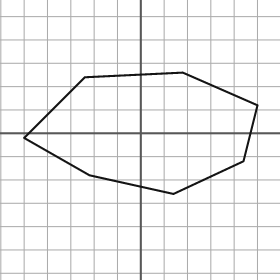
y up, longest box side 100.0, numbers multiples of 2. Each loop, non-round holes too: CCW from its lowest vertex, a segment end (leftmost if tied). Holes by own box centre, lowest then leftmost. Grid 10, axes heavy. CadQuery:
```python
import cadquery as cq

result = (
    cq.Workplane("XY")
    .moveTo(14.0, -26.0)
    .lineTo(44.0, -12.0)
    .lineTo(50.0, 12.0)
    .lineTo(18.0, 26.0)
    .lineTo(-24.0, 24.0)
    .lineTo(-50.0, -2.0)
    .lineTo(-22.0, -18.0)
    .close()
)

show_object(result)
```